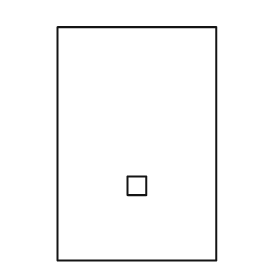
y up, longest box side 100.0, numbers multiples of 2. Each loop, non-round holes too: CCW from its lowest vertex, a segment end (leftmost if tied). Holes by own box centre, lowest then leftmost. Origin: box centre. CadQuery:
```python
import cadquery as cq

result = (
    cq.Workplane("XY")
    .moveTo(-34.0, -50.0)
    .lineTo(34.0, -50.0)
    .lineTo(34.0, 50.0)
    .lineTo(-34.0, 50.0)
    .close()
    .moveTo(-4.0, -22.0)
    .lineTo(4.0, -22.0)
    .lineTo(4.0, -14.0)
    .lineTo(-4.0, -14.0)
    .close()
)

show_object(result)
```